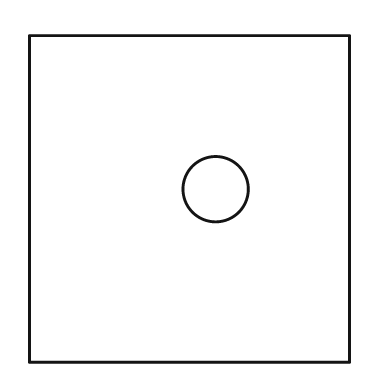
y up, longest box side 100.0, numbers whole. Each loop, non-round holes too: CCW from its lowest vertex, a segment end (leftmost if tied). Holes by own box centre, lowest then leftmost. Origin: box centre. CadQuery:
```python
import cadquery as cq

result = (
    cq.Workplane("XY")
    .moveTo(-49.0, -50.0)
    .lineTo(49.0, -50.0)
    .lineTo(49.0, 50.0)
    .lineTo(-49.0, 50.0)
    .close()
    .moveTo(8.0, 3.0)
    .circle(10.0)
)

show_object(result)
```